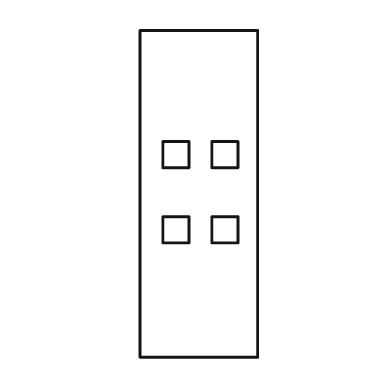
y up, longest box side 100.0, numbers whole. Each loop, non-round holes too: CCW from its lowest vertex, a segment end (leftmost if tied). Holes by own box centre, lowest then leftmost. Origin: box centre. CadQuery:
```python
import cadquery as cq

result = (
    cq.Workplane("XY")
    .moveTo(-18.0, -50.0)
    .lineTo(18.0, -50.0)
    .lineTo(18.0, 50.0)
    .lineTo(-18.0, 50.0)
    .close()
    .moveTo(-11.0, -15.0)
    .lineTo(-3.0, -15.0)
    .lineTo(-3.0, -7.0)
    .lineTo(-11.0, -7.0)
    .close()
    .moveTo(4.0, -15.0)
    .lineTo(12.0, -15.0)
    .lineTo(12.0, -7.0)
    .lineTo(4.0, -7.0)
    .close()
    .moveTo(-11.0, 8.0)
    .lineTo(-3.0, 8.0)
    .lineTo(-3.0, 16.0)
    .lineTo(-11.0, 16.0)
    .close()
    .moveTo(4.0, 8.0)
    .lineTo(12.0, 8.0)
    .lineTo(12.0, 16.0)
    .lineTo(4.0, 16.0)
    .close()
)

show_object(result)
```